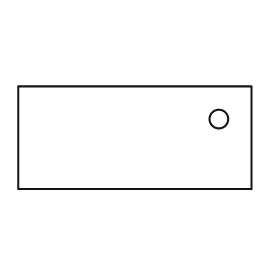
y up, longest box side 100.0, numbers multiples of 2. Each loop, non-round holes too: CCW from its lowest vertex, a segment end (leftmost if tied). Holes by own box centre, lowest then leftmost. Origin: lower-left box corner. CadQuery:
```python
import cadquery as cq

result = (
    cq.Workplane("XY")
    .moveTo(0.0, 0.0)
    .lineTo(100.0, 0.0)
    .lineTo(100.0, 44.0)
    .lineTo(0.0, 44.0)
    .close()
    .moveTo(86.0, 30.0)
    .circle(4.0)
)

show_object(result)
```